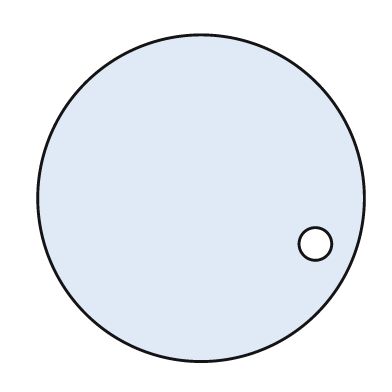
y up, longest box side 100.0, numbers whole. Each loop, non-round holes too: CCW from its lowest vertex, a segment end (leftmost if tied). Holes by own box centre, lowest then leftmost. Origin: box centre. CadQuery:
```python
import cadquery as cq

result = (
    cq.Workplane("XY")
    .moveTo(0.0, 0.0)
    .circle(50.0)
    .moveTo(35.0, -14.0)
    .circle(5.0)
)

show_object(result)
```